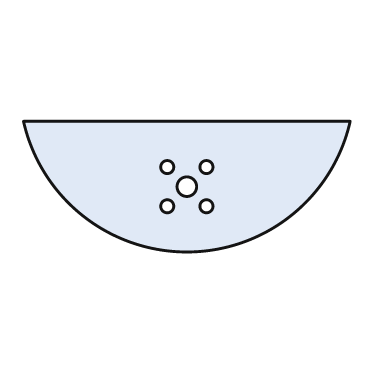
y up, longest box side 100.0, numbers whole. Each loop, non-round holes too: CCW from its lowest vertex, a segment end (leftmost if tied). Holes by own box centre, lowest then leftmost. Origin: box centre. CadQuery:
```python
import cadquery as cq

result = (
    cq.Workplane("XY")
    .moveTo(-50.0, 20.0)
    .threePointArc((0.0, -20.0), (50.0, 20.0))
    .close()
    .moveTo(-6.0, -6.0)
    .circle(2.0)
    .moveTo(6.0, -6.0)
    .circle(2.0)
    .moveTo(0.0, 0.0)
    .circle(3.0)
    .moveTo(-6.0, 6.0)
    .circle(2.0)
    .moveTo(6.0, 6.0)
    .circle(2.0)
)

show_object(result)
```